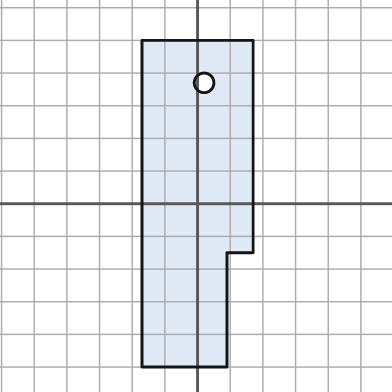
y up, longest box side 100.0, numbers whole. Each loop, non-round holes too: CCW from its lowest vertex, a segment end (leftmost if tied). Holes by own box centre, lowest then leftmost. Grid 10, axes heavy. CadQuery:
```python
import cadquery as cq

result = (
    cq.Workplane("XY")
    .moveTo(-17.0, -50.0)
    .lineTo(9.0, -50.0)
    .lineTo(9.0, -15.0)
    .lineTo(17.0, -15.0)
    .lineTo(17.0, 50.0)
    .lineTo(-17.0, 50.0)
    .close()
    .moveTo(2.0, 37.0)
    .circle(3.0)
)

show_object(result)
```